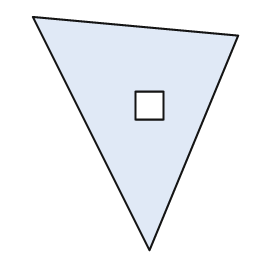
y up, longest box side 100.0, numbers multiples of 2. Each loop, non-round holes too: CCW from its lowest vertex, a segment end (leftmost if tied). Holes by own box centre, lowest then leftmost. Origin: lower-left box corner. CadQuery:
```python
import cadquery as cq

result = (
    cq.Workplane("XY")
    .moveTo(50.0, 0.0)
    .lineTo(88.0, 92.0)
    .lineTo(0.0, 100.0)
    .close()
    .moveTo(44.0, 56.0)
    .lineTo(56.0, 56.0)
    .lineTo(56.0, 68.0)
    .lineTo(44.0, 68.0)
    .close()
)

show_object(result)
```